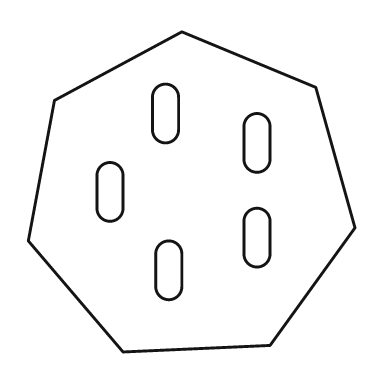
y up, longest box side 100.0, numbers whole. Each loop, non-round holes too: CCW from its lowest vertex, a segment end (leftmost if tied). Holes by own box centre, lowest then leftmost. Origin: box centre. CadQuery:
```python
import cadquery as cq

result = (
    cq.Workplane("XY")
    .moveTo(-21.0, -49.0)
    .lineTo(24.0, -47.0)
    .lineTo(50.0, -11.0)
    .lineTo(38.0, 32.0)
    .lineTo(-3.0, 49.0)
    .lineTo(-42.0, 28.0)
    .lineTo(-50.0, -15.0)
    .close()
    .moveTo(-11.0, -29.0)
    .threePointArc((-7.0, -33.0), (-3.0, -29.0))
    .lineTo(-3.0, -19.0)
    .threePointArc((-7.0, -15.0), (-11.0, -19.0))
    .close()
    .moveTo(16.0, -19.0)
    .threePointArc((20.0, -23.0), (24.0, -19.0))
    .lineTo(24.0, -9.0)
    .threePointArc((20.0, -5.0), (16.0, -9.0))
    .close()
    .moveTo(-29.0, -5.0)
    .threePointArc((-25.0, -9.0), (-21.0, -5.0))
    .lineTo(-21.0, 5.0)
    .threePointArc((-25.0, 9.0), (-29.0, 5.0))
    .close()
    .moveTo(16.0, 10.0)
    .threePointArc((20.0, 6.0), (24.0, 10.0))
    .lineTo(24.0, 20.0)
    .threePointArc((20.0, 24.0), (16.0, 20.0))
    .close()
    .moveTo(-12.0, 19.0)
    .threePointArc((-8.0, 15.0), (-4.0, 19.0))
    .lineTo(-4.0, 29.0)
    .threePointArc((-8.0, 33.0), (-12.0, 29.0))
    .close()
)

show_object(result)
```